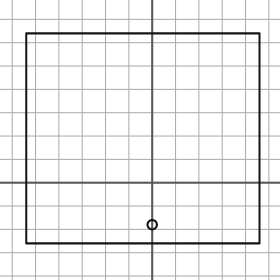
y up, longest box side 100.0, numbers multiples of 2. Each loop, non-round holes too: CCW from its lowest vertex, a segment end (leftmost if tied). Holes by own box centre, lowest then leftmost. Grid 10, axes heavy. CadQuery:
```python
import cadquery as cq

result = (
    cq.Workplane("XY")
    .moveTo(-54.0, -26.0)
    .lineTo(46.0, -26.0)
    .lineTo(46.0, 64.0)
    .lineTo(-54.0, 64.0)
    .close()
    .moveTo(0.0, -18.0)
    .circle(2.0)
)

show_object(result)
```